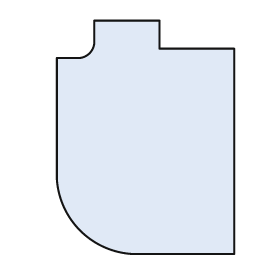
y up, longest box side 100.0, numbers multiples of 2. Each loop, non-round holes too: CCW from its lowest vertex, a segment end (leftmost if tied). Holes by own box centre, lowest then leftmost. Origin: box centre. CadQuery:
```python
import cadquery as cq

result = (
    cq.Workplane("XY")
    .moveTo(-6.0, -50.0)
    .lineTo(38.0, -50.0)
    .lineTo(38.0, 38.0)
    .lineTo(6.0, 38.0)
    .lineTo(6.0, 50.0)
    .lineTo(-22.0, 50.0)
    .lineTo(-22.0, 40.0)
    .threePointArc((-24.0, 36.0), (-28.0, 34.0))
    .lineTo(-38.0, 34.0)
    .lineTo(-38.0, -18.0)
    .threePointArc((-28.0, -40.0), (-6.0, -50.0))
    .close()
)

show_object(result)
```